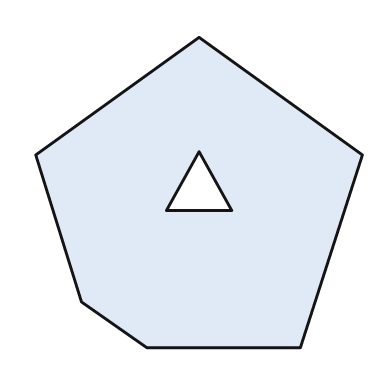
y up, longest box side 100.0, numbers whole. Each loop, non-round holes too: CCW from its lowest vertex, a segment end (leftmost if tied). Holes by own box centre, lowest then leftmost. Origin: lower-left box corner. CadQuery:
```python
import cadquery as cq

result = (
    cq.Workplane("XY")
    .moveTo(34.0, 0.0)
    .lineTo(81.0, 0.0)
    .lineTo(100.0, 59.0)
    .lineTo(50.0, 95.0)
    .lineTo(0.0, 59.0)
    .lineTo(14.0, 14.0)
    .close()
    .moveTo(40.0, 42.0)
    .lineTo(60.0, 42.0)
    .lineTo(50.0, 60.0)
    .close()
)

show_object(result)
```